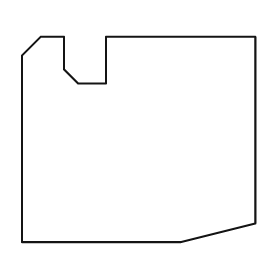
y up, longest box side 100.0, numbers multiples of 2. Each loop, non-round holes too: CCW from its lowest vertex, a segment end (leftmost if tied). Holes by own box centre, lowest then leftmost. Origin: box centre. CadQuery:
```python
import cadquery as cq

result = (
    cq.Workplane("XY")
    .moveTo(-50.0, -44.0)
    .lineTo(18.0, -44.0)
    .lineTo(50.0, -36.0)
    .lineTo(50.0, 44.0)
    .lineTo(-14.0, 44.0)
    .lineTo(-14.0, 24.0)
    .lineTo(-26.0, 24.0)
    .lineTo(-32.0, 30.0)
    .lineTo(-32.0, 44.0)
    .lineTo(-42.0, 44.0)
    .lineTo(-50.0, 36.0)
    .close()
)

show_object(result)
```